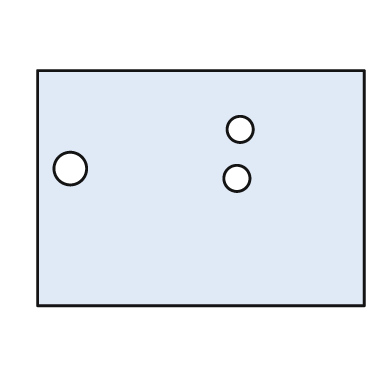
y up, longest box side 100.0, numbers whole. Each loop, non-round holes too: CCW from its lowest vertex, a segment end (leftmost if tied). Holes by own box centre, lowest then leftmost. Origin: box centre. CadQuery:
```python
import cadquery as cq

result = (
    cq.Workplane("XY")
    .moveTo(-50.0, -36.0)
    .lineTo(50.0, -36.0)
    .lineTo(50.0, 36.0)
    .lineTo(-50.0, 36.0)
    .close()
    .moveTo(11.0, 3.0)
    .circle(4.0)
    .moveTo(-40.0, 6.0)
    .circle(5.0)
    .moveTo(12.0, 18.0)
    .circle(4.0)
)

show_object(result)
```